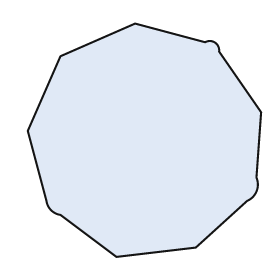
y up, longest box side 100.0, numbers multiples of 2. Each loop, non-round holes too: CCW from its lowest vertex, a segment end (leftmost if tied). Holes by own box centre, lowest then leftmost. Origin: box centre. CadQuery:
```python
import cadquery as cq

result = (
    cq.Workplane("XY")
    .moveTo(-12.0, -50.0)
    .lineTo(22.0, -46.0)
    .lineTo(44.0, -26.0)
    .threePointArc((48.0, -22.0), (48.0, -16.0))
    .lineTo(50.0, 12.0)
    .lineTo(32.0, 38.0)
    .threePointArc((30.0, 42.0), (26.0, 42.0))
    .lineTo(-4.0, 50.0)
    .lineTo(-36.0, 36.0)
    .lineTo(-50.0, 4.0)
    .lineTo(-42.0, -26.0)
    .threePointArc((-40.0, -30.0), (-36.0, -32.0))
    .close()
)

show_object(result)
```